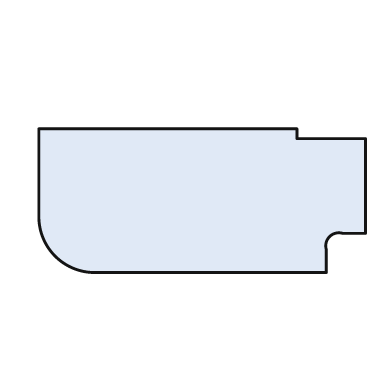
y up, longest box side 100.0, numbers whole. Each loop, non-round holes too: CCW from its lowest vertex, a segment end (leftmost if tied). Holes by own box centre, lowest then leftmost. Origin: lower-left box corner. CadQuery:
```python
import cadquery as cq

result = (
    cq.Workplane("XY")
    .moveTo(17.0, 0.0)
    .lineTo(88.0, 0.0)
    .lineTo(88.0, 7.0)
    .threePointArc((89.0, 11.0), (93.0, 12.0))
    .lineTo(100.0, 12.0)
    .lineTo(100.0, 41.0)
    .lineTo(79.0, 41.0)
    .lineTo(79.0, 44.0)
    .lineTo(0.0, 44.0)
    .lineTo(0.0, 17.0)
    .threePointArc((5.0, 5.0), (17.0, 0.0))
    .close()
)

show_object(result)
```